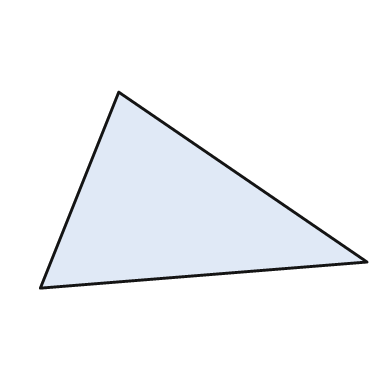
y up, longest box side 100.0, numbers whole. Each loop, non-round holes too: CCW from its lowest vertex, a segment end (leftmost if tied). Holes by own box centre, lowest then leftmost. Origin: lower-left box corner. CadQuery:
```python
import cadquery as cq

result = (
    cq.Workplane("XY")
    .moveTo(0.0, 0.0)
    .lineTo(100.0, 8.0)
    .lineTo(24.0, 60.0)
    .close()
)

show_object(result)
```